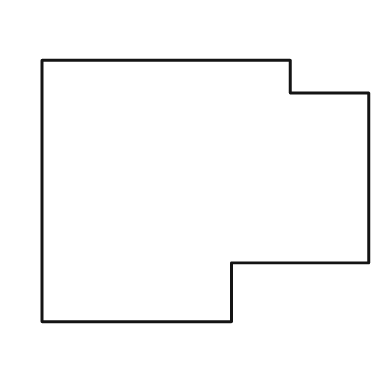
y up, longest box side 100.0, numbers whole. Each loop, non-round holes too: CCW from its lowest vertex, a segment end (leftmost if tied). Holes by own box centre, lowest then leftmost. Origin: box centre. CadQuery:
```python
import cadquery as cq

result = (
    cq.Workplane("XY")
    .moveTo(-50.0, -40.0)
    .lineTo(8.0, -40.0)
    .lineTo(8.0, -22.0)
    .lineTo(50.0, -22.0)
    .lineTo(50.0, 30.0)
    .lineTo(26.0, 30.0)
    .lineTo(26.0, 40.0)
    .lineTo(-50.0, 40.0)
    .close()
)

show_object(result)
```